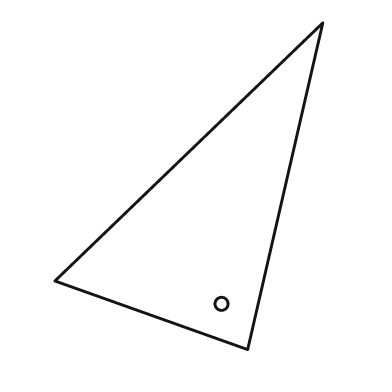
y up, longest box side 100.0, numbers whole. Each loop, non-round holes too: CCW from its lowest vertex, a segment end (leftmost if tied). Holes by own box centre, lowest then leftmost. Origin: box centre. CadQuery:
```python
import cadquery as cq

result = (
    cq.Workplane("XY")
    .moveTo(18.0, -50.0)
    .lineTo(41.0, 50.0)
    .lineTo(-41.0, -29.0)
    .close()
    .moveTo(10.0, -36.0)
    .circle(2.0)
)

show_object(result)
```